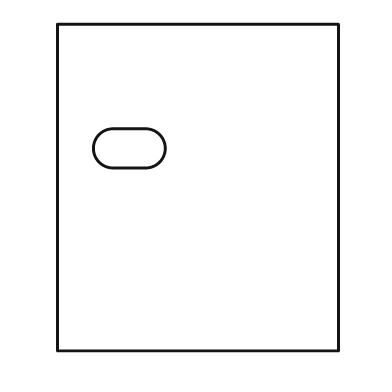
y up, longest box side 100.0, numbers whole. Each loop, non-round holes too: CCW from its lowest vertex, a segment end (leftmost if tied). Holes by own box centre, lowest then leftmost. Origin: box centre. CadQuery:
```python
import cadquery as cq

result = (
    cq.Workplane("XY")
    .moveTo(-43.0, -50.0)
    .lineTo(43.0, -50.0)
    .lineTo(43.0, 50.0)
    .lineTo(-43.0, 50.0)
    .close()
    .moveTo(-26.0, 6.0)
    .lineTo(-16.0, 6.0)
    .threePointArc((-10.0, 12.0), (-16.0, 18.0))
    .lineTo(-26.0, 18.0)
    .threePointArc((-32.0, 12.0), (-26.0, 6.0))
    .close()
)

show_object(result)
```